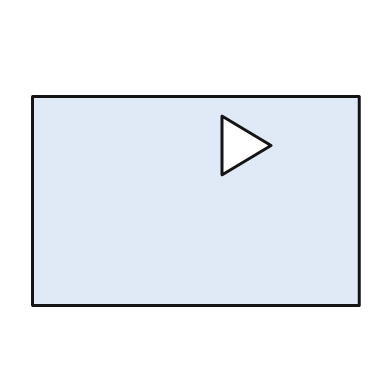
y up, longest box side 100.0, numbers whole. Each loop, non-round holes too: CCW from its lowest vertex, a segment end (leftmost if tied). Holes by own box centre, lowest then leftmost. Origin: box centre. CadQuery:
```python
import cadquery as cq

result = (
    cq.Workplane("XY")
    .moveTo(-50.0, -32.0)
    .lineTo(50.0, -32.0)
    .lineTo(50.0, 32.0)
    .lineTo(-50.0, 32.0)
    .close()
    .moveTo(8.0, 8.0)
    .lineTo(23.0, 17.0)
    .lineTo(8.0, 26.0)
    .close()
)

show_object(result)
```